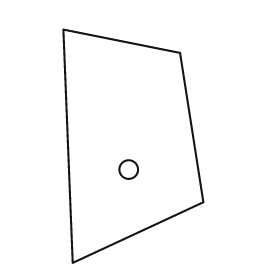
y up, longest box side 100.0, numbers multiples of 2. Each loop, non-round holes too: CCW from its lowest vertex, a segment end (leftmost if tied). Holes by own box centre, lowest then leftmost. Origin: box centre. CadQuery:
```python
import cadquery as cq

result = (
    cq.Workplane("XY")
    .moveTo(-26.0, -50.0)
    .lineTo(30.0, -24.0)
    .lineTo(20.0, 40.0)
    .lineTo(-30.0, 50.0)
    .close()
    .moveTo(-2.0, -10.0)
    .circle(4.0)
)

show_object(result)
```